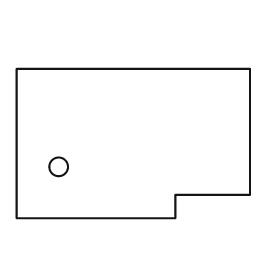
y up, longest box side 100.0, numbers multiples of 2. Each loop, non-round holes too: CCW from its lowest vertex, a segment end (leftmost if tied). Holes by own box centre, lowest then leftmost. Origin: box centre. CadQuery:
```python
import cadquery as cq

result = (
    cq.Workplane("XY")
    .moveTo(-50.0, -32.0)
    .lineTo(18.0, -32.0)
    .lineTo(18.0, -22.0)
    .lineTo(50.0, -22.0)
    .lineTo(50.0, 32.0)
    .lineTo(-50.0, 32.0)
    .close()
    .moveTo(-32.0, -10.0)
    .circle(4.0)
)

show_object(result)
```